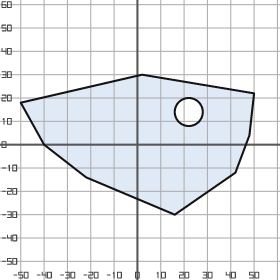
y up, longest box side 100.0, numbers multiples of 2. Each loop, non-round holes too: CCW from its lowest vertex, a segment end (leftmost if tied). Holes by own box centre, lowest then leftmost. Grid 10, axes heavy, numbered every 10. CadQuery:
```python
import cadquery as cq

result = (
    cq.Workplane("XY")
    .moveTo(16.0, -30.0)
    .lineTo(42.0, -12.0)
    .lineTo(48.0, 4.0)
    .lineTo(50.0, 22.0)
    .lineTo(2.0, 30.0)
    .lineTo(-50.0, 18.0)
    .lineTo(-40.0, 0.0)
    .lineTo(-22.0, -14.0)
    .close()
    .moveTo(22.0, 14.0)
    .circle(6.0)
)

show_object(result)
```